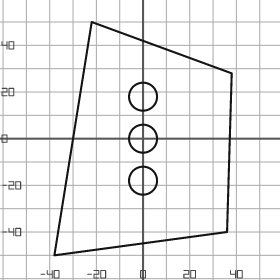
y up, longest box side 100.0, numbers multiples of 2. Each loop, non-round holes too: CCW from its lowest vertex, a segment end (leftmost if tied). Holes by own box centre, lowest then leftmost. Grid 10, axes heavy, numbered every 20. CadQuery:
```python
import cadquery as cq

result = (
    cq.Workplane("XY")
    .moveTo(-38.0, -50.0)
    .lineTo(36.0, -40.0)
    .lineTo(38.0, 28.0)
    .lineTo(-22.0, 50.0)
    .close()
    .moveTo(0.0, -18.0)
    .circle(6.0)
    .moveTo(0.0, 0.0)
    .circle(6.0)
    .moveTo(0.0, 18.0)
    .circle(6.0)
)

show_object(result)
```